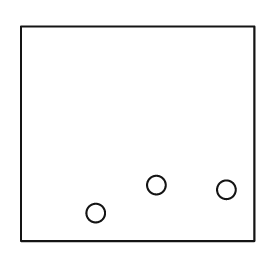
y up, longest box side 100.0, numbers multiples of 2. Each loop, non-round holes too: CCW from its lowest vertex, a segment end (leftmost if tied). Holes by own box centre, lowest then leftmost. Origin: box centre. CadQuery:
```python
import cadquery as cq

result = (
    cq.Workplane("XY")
    .moveTo(-50.0, -46.0)
    .lineTo(50.0, -46.0)
    .lineTo(50.0, 46.0)
    .lineTo(-50.0, 46.0)
    .close()
    .moveTo(-18.0, -34.0)
    .circle(4.0)
    .moveTo(38.0, -24.0)
    .circle(4.0)
    .moveTo(8.0, -22.0)
    .circle(4.0)
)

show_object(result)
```